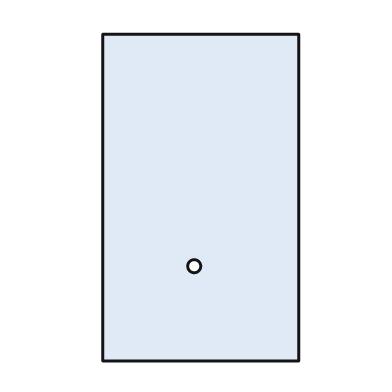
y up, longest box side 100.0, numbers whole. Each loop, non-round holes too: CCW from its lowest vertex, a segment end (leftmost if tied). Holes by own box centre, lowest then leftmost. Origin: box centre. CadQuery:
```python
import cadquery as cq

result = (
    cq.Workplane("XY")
    .moveTo(-30.0, -50.0)
    .lineTo(30.0, -50.0)
    .lineTo(30.0, 50.0)
    .lineTo(-30.0, 50.0)
    .close()
    .moveTo(-2.0, -21.0)
    .circle(2.0)
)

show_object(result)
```